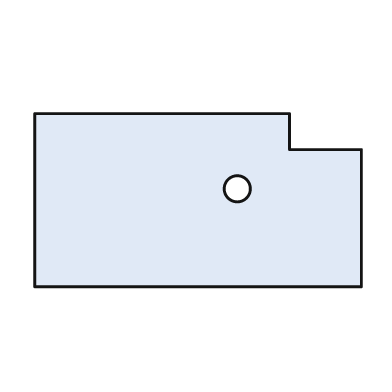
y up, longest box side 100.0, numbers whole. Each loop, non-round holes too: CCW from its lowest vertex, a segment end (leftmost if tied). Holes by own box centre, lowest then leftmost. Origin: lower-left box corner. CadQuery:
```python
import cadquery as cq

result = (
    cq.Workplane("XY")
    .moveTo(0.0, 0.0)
    .lineTo(100.0, 0.0)
    .lineTo(100.0, 42.0)
    .lineTo(78.0, 42.0)
    .lineTo(78.0, 53.0)
    .lineTo(0.0, 53.0)
    .close()
    .moveTo(62.0, 30.0)
    .circle(4.0)
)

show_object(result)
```